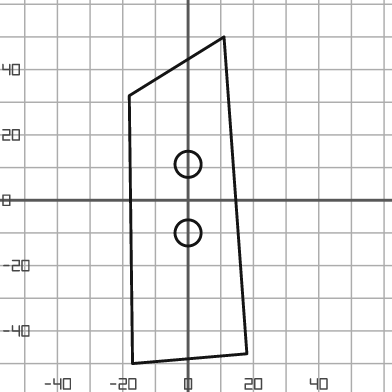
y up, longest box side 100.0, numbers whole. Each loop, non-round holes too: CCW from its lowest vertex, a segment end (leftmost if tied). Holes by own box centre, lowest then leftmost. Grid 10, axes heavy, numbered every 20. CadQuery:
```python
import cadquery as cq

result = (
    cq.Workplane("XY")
    .moveTo(-17.0, -50.0)
    .lineTo(18.0, -47.0)
    .lineTo(11.0, 50.0)
    .lineTo(-18.0, 32.0)
    .close()
    .moveTo(0.0, -10.0)
    .circle(4.0)
    .moveTo(0.0, 11.0)
    .circle(4.0)
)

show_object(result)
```